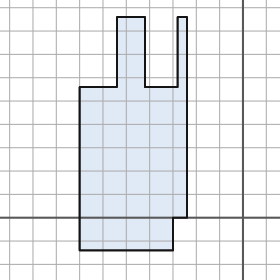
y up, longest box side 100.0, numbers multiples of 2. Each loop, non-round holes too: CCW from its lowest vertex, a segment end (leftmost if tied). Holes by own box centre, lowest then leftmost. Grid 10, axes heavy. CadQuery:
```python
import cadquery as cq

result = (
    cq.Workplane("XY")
    .moveTo(-70.0, -14.0)
    .lineTo(-30.0, -14.0)
    .lineTo(-30.0, 0.0)
    .lineTo(-24.0, 0.0)
    .lineTo(-24.0, 86.0)
    .lineTo(-28.0, 86.0)
    .lineTo(-28.0, 56.0)
    .lineTo(-42.0, 56.0)
    .lineTo(-42.0, 86.0)
    .lineTo(-54.0, 86.0)
    .lineTo(-54.0, 56.0)
    .lineTo(-70.0, 56.0)
    .close()
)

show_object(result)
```